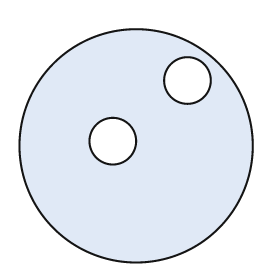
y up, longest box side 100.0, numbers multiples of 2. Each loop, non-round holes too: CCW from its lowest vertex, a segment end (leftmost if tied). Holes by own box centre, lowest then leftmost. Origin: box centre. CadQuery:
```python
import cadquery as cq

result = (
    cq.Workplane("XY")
    .moveTo(0.0, 0.0)
    .circle(50.0)
    .moveTo(-10.0, 2.0)
    .circle(10.0)
    .moveTo(22.0, 28.0)
    .circle(10.0)
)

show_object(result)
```